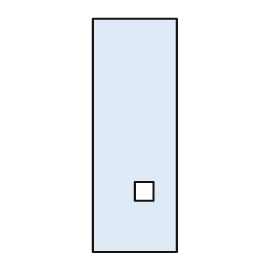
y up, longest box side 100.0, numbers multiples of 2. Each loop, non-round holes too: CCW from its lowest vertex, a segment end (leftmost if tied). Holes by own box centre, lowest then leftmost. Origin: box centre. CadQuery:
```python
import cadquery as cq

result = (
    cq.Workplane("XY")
    .moveTo(-18.0, -50.0)
    .lineTo(18.0, -50.0)
    .lineTo(18.0, 50.0)
    .lineTo(-18.0, 50.0)
    .close()
    .moveTo(0.0, -28.0)
    .lineTo(8.0, -28.0)
    .lineTo(8.0, -20.0)
    .lineTo(0.0, -20.0)
    .close()
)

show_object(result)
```